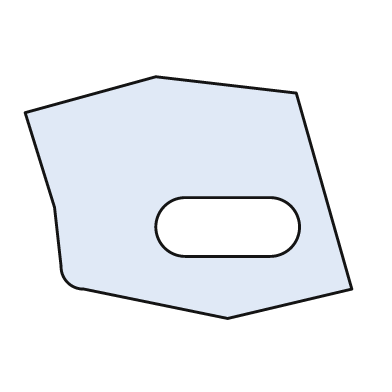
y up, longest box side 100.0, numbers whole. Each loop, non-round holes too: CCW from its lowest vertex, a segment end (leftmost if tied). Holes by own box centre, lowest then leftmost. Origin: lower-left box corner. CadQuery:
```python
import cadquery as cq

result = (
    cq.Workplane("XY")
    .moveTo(62.0, 0.0)
    .lineTo(100.0, 9.0)
    .lineTo(83.0, 69.0)
    .lineTo(40.0, 74.0)
    .lineTo(0.0, 63.0)
    .lineTo(9.0, 34.0)
    .lineTo(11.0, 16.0)
    .threePointArc((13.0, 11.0), (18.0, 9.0))
    .close()
    .moveTo(49.0, 19.0)
    .lineTo(75.0, 19.0)
    .threePointArc((84.0, 28.0), (75.0, 37.0))
    .lineTo(49.0, 37.0)
    .threePointArc((40.0, 28.0), (49.0, 19.0))
    .close()
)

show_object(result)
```